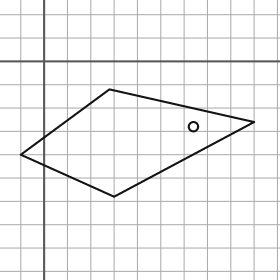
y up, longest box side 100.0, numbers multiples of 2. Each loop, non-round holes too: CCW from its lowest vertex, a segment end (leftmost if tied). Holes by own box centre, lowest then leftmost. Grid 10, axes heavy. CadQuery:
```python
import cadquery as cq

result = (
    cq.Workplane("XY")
    .moveTo(30.0, -58.0)
    .lineTo(90.0, -26.0)
    .lineTo(28.0, -12.0)
    .lineTo(-10.0, -40.0)
    .close()
    .moveTo(64.0, -28.0)
    .circle(2.0)
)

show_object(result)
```